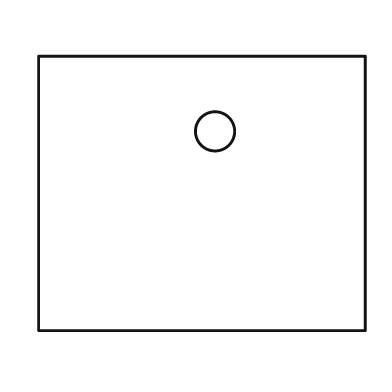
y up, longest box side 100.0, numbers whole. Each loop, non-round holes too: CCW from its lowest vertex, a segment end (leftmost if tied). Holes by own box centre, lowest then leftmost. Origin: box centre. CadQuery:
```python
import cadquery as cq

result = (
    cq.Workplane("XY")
    .moveTo(-50.0, -42.0)
    .lineTo(50.0, -42.0)
    .lineTo(50.0, 42.0)
    .lineTo(-50.0, 42.0)
    .close()
    .moveTo(4.0, 19.0)
    .circle(6.0)
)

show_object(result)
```